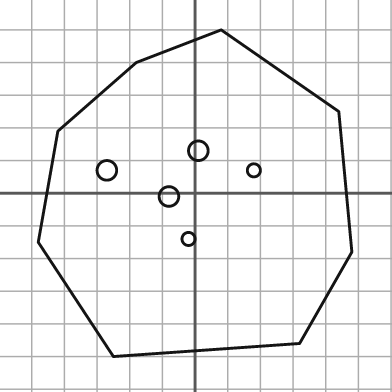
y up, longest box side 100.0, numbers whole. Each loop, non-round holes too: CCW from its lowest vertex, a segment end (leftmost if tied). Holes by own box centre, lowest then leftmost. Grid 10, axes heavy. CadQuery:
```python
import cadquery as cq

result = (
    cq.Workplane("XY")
    .moveTo(-25.0, -50.0)
    .lineTo(32.0, -46.0)
    .lineTo(48.0, -18.0)
    .lineTo(44.0, 25.0)
    .lineTo(8.0, 50.0)
    .lineTo(-18.0, 40.0)
    .lineTo(-42.0, 19.0)
    .lineTo(-48.0, -15.0)
    .close()
    .moveTo(-2.0, -14.0)
    .circle(2.0)
    .moveTo(-8.0, -1.0)
    .circle(3.0)
    .moveTo(-27.0, 7.0)
    .circle(3.0)
    .moveTo(18.0, 7.0)
    .circle(2.0)
    .moveTo(1.0, 13.0)
    .circle(3.0)
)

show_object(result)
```